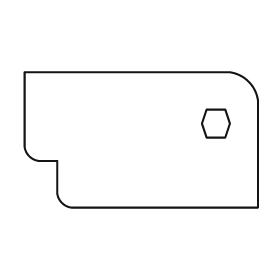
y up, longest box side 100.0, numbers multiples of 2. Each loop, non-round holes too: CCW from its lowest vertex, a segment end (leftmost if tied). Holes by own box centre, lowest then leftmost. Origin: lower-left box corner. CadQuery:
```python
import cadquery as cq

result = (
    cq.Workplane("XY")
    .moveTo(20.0, 0.0)
    .lineTo(100.0, 0.0)
    .lineTo(100.0, 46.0)
    .threePointArc((96.0, 54.0), (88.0, 58.0))
    .lineTo(0.0, 58.0)
    .lineTo(0.0, 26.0)
    .threePointArc((2.0, 22.0), (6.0, 20.0))
    .lineTo(14.0, 20.0)
    .lineTo(14.0, 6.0)
    .threePointArc((16.0, 2.0), (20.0, 0.0))
    .close()
    .moveTo(78.0, 30.0)
    .lineTo(86.0, 30.0)
    .lineTo(88.0, 36.0)
    .lineTo(86.0, 42.0)
    .lineTo(78.0, 42.0)
    .lineTo(76.0, 36.0)
    .close()
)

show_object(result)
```